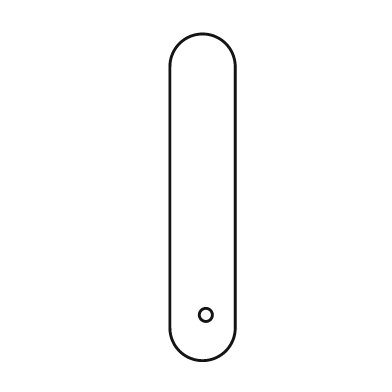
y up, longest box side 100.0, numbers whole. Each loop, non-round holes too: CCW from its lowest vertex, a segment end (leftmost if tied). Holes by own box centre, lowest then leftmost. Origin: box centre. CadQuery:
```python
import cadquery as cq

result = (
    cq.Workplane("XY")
    .moveTo(-10.0, -40.0)
    .threePointArc((0.0, -50.0), (10.0, -40.0))
    .lineTo(10.0, 40.0)
    .threePointArc((0.0, 50.0), (-10.0, 40.0))
    .close()
    .moveTo(1.0, -36.0)
    .circle(2.0)
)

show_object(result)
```